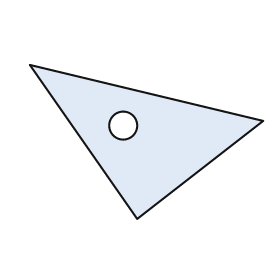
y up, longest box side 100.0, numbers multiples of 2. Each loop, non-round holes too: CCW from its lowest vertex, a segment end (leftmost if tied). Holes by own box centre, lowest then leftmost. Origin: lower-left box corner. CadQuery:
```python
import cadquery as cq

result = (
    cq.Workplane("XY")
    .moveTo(46.0, 0.0)
    .lineTo(100.0, 42.0)
    .lineTo(0.0, 66.0)
    .close()
    .moveTo(40.0, 40.0)
    .circle(6.0)
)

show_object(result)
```